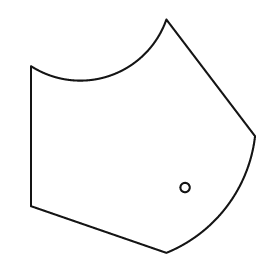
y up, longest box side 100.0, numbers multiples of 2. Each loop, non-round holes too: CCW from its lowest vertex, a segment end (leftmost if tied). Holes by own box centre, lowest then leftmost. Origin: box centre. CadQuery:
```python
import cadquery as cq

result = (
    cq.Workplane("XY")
    .moveTo(10.0, -50.0)
    .threePointArc((36.0, -30.0), (48.0, 0.0))
    .lineTo(10.0, 50.0)
    .threePointArc((-14.0, 26.0), (-48.0, 30.0))
    .lineTo(-48.0, -30.0)
    .close()
    .moveTo(18.0, -22.0)
    .circle(2.0)
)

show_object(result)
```